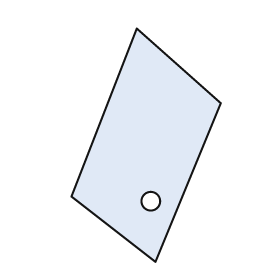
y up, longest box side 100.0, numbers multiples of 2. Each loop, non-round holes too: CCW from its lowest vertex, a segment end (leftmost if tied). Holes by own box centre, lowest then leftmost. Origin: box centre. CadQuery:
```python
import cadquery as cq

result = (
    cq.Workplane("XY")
    .moveTo(4.0, -50.0)
    .lineTo(32.0, 18.0)
    .lineTo(-4.0, 50.0)
    .lineTo(-32.0, -22.0)
    .close()
    .moveTo(2.0, -24.0)
    .circle(4.0)
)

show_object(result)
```